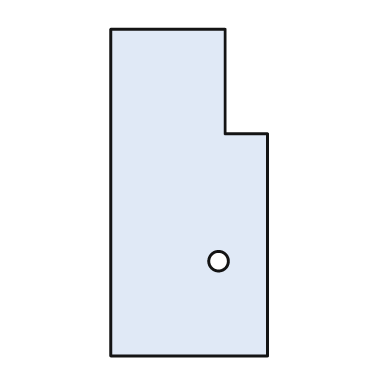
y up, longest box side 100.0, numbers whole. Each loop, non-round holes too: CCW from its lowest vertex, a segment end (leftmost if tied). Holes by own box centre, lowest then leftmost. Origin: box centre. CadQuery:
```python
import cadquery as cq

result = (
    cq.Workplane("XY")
    .moveTo(-24.0, -50.0)
    .lineTo(24.0, -50.0)
    .lineTo(24.0, 18.0)
    .lineTo(11.0, 18.0)
    .lineTo(11.0, 50.0)
    .lineTo(-24.0, 50.0)
    .close()
    .moveTo(9.0, -21.0)
    .circle(3.0)
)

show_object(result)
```